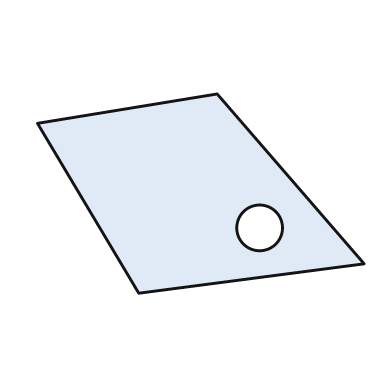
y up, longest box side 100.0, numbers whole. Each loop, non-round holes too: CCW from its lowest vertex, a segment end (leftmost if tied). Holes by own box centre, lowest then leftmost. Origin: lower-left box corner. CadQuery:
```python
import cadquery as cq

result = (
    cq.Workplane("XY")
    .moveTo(31.0, 0.0)
    .lineTo(100.0, 9.0)
    .lineTo(55.0, 61.0)
    .lineTo(0.0, 52.0)
    .close()
    .moveTo(68.0, 20.0)
    .circle(7.0)
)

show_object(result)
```